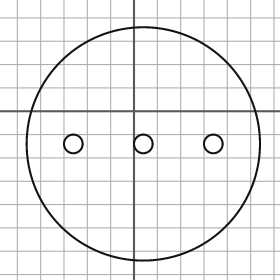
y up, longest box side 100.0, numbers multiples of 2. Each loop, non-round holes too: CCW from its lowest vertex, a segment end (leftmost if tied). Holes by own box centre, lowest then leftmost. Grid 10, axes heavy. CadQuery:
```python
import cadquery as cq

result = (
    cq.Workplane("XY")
    .moveTo(4.0, -14.0)
    .circle(50.0)
    .moveTo(-26.0, -14.0)
    .circle(4.0)
    .moveTo(4.0, -14.0)
    .circle(4.0)
    .moveTo(34.0, -14.0)
    .circle(4.0)
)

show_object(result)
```